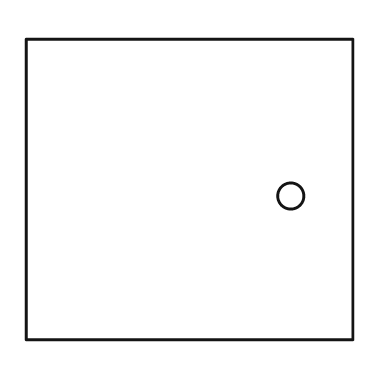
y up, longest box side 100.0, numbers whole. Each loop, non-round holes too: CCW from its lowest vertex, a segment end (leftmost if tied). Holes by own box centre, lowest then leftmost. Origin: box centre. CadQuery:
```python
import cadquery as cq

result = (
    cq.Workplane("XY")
    .moveTo(-50.0, -46.0)
    .lineTo(50.0, -46.0)
    .lineTo(50.0, 46.0)
    .lineTo(-50.0, 46.0)
    .close()
    .moveTo(31.0, -2.0)
    .circle(4.0)
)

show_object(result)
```